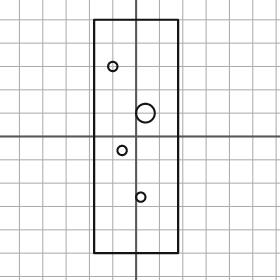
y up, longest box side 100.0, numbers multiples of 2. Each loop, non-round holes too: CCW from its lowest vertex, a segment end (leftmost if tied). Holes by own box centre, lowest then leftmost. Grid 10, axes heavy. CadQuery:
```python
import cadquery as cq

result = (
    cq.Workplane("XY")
    .moveTo(-18.0, -50.0)
    .lineTo(18.0, -50.0)
    .lineTo(18.0, 50.0)
    .lineTo(-18.0, 50.0)
    .close()
    .moveTo(2.0, -26.0)
    .circle(2.0)
    .moveTo(-6.0, -6.0)
    .circle(2.0)
    .moveTo(4.0, 10.0)
    .circle(4.0)
    .moveTo(-10.0, 30.0)
    .circle(2.0)
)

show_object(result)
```